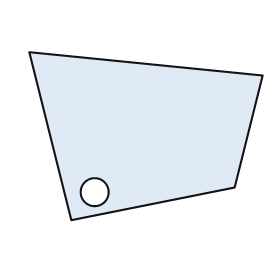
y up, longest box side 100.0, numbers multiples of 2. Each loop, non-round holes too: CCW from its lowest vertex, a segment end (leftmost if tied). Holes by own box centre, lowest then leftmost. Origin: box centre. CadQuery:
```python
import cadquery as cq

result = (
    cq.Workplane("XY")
    .moveTo(-32.0, -36.0)
    .lineTo(38.0, -22.0)
    .lineTo(50.0, 26.0)
    .lineTo(-50.0, 36.0)
    .close()
    .moveTo(-22.0, -24.0)
    .circle(6.0)
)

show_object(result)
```